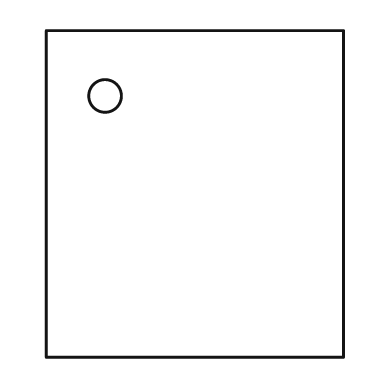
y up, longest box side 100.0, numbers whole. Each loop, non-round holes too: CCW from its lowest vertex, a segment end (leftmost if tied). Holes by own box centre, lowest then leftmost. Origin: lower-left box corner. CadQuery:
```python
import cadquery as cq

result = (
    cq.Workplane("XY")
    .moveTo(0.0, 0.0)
    .lineTo(91.0, 0.0)
    .lineTo(91.0, 100.0)
    .lineTo(0.0, 100.0)
    .close()
    .moveTo(18.0, 80.0)
    .circle(5.0)
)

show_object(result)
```